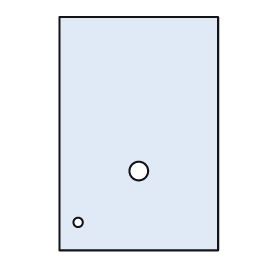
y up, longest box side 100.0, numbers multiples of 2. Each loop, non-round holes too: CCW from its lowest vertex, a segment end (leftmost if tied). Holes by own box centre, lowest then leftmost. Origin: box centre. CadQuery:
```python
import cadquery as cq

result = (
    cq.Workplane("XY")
    .moveTo(-34.0, -50.0)
    .lineTo(34.0, -50.0)
    .lineTo(34.0, 50.0)
    .lineTo(-34.0, 50.0)
    .close()
    .moveTo(-26.0, -38.0)
    .circle(2.0)
    .moveTo(0.0, -16.0)
    .circle(4.0)
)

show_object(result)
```